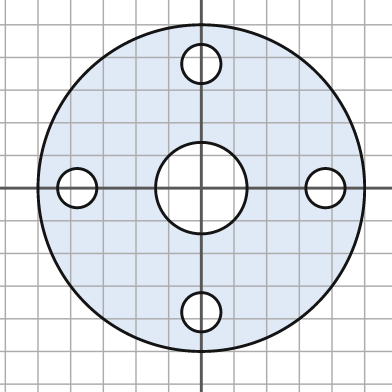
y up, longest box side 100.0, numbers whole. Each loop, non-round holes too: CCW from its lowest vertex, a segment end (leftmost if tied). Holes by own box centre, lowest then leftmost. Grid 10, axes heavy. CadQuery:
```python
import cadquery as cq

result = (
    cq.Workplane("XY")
    .moveTo(0.0, 0.0)
    .circle(50.0)
    .moveTo(0.0, -38.0)
    .circle(6.0)
    .moveTo(-38.0, 0.0)
    .circle(6.0)
    .moveTo(0.0, 0.0)
    .circle(14.0)
    .moveTo(38.0, 0.0)
    .circle(6.0)
    .moveTo(0.0, 38.0)
    .circle(6.0)
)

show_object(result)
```